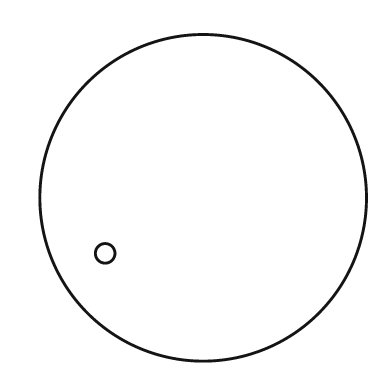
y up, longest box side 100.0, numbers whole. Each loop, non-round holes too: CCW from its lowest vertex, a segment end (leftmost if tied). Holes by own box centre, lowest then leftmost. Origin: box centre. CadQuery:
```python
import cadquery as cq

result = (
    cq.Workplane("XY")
    .moveTo(0.0, 0.0)
    .circle(50.0)
    .moveTo(-30.0, -17.0)
    .circle(3.0)
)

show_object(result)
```